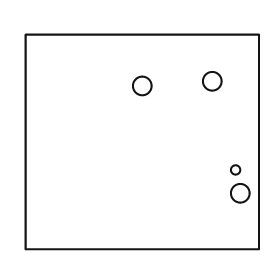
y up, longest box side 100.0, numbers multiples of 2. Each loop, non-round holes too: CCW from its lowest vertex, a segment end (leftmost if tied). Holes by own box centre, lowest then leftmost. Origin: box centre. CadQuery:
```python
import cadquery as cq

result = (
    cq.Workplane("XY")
    .moveTo(-50.0, -46.0)
    .lineTo(50.0, -46.0)
    .lineTo(50.0, 46.0)
    .lineTo(-50.0, 46.0)
    .close()
    .moveTo(42.0, -22.0)
    .circle(4.0)
    .moveTo(40.0, -12.0)
    .circle(2.0)
    .moveTo(0.0, 24.0)
    .circle(4.0)
    .moveTo(30.0, 26.0)
    .circle(4.0)
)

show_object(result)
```